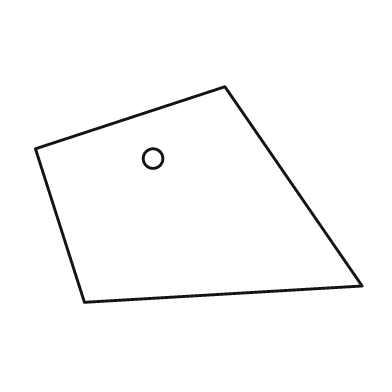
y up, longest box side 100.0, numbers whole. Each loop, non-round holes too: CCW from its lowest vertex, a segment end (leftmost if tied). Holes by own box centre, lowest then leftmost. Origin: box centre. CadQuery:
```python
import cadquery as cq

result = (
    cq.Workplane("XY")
    .moveTo(-35.0, -33.0)
    .lineTo(50.0, -28.0)
    .lineTo(8.0, 33.0)
    .lineTo(-50.0, 14.0)
    .close()
    .moveTo(-14.0, 11.0)
    .circle(3.0)
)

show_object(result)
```